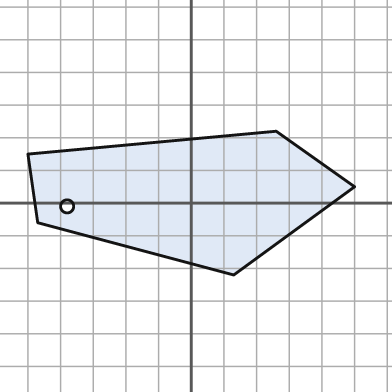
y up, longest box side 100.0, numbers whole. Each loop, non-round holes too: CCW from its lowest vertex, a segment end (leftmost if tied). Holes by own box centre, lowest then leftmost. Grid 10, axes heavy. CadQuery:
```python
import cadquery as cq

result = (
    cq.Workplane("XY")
    .moveTo(13.0, -22.0)
    .lineTo(50.0, 5.0)
    .lineTo(26.0, 22.0)
    .lineTo(-50.0, 15.0)
    .lineTo(-47.0, -6.0)
    .close()
    .moveTo(-38.0, -1.0)
    .circle(2.0)
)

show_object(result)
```